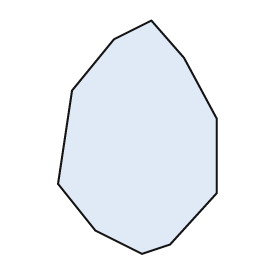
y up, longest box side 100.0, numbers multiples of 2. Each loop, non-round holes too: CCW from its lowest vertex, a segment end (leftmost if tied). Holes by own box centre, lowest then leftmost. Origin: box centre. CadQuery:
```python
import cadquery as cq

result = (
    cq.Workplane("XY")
    .moveTo(2.0, -50.0)
    .lineTo(14.0, -46.0)
    .lineTo(34.0, -24.0)
    .lineTo(34.0, 8.0)
    .lineTo(20.0, 34.0)
    .lineTo(6.0, 50.0)
    .lineTo(-10.0, 42.0)
    .lineTo(-28.0, 20.0)
    .lineTo(-34.0, -20.0)
    .lineTo(-18.0, -40.0)
    .close()
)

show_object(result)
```